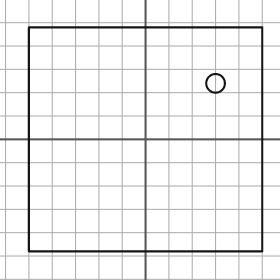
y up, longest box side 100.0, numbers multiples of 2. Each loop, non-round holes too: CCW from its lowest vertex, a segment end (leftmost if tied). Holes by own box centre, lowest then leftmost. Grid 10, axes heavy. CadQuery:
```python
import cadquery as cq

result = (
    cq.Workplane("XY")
    .moveTo(-50.0, -48.0)
    .lineTo(50.0, -48.0)
    .lineTo(50.0, 48.0)
    .lineTo(-50.0, 48.0)
    .close()
    .moveTo(30.0, 24.0)
    .circle(4.0)
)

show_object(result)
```